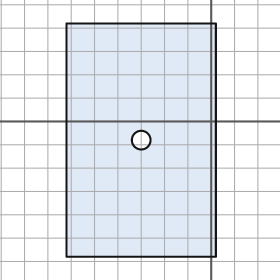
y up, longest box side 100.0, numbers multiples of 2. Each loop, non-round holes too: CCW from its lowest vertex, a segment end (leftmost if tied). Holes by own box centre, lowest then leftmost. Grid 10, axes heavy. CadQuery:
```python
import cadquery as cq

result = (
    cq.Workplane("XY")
    .moveTo(-62.0, -58.0)
    .lineTo(2.0, -58.0)
    .lineTo(2.0, 42.0)
    .lineTo(-62.0, 42.0)
    .close()
    .moveTo(-30.0, -8.0)
    .circle(4.0)
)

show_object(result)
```